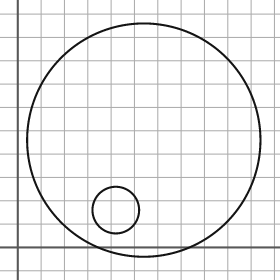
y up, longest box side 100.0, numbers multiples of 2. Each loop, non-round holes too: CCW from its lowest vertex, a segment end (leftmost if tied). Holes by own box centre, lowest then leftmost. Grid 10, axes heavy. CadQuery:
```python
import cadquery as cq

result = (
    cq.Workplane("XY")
    .moveTo(54.0, 46.0)
    .circle(50.0)
    .moveTo(42.0, 16.0)
    .circle(10.0)
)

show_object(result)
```